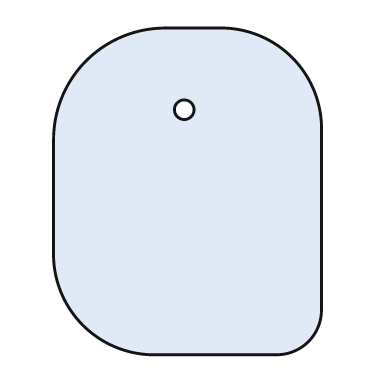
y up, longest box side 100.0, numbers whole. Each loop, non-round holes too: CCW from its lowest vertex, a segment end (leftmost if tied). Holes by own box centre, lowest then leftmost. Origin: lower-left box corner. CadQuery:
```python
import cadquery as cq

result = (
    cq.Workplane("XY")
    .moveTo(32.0, 0.0)
    .lineTo(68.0, 0.0)
    .threePointArc((78.0, 4.0), (82.0, 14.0))
    .lineTo(82.0, 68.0)
    .threePointArc((73.0, 91.0), (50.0, 100.0))
    .lineTo(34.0, 100.0)
    .threePointArc((10.0, 90.0), (0.0, 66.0))
    .lineTo(0.0, 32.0)
    .threePointArc((9.0, 9.0), (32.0, 0.0))
    .close()
    .moveTo(40.0, 75.0)
    .circle(3.0)
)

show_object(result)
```